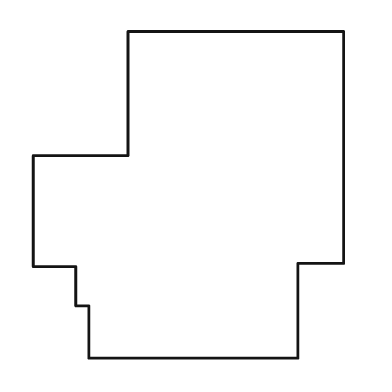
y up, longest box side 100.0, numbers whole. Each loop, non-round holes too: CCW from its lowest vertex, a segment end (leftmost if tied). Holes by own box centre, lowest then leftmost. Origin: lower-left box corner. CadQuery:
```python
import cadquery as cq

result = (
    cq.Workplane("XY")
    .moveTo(17.0, 0.0)
    .lineTo(81.0, 0.0)
    .lineTo(81.0, 29.0)
    .lineTo(95.0, 29.0)
    .lineTo(95.0, 100.0)
    .lineTo(29.0, 100.0)
    .lineTo(29.0, 62.0)
    .lineTo(0.0, 62.0)
    .lineTo(0.0, 28.0)
    .lineTo(13.0, 28.0)
    .lineTo(13.0, 16.0)
    .lineTo(17.0, 16.0)
    .close()
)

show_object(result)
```